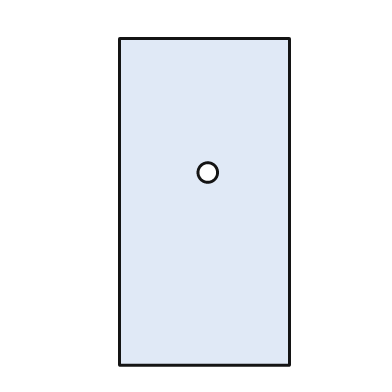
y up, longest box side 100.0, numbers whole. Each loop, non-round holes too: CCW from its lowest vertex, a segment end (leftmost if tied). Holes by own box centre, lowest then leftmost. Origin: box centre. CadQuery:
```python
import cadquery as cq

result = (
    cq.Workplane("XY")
    .moveTo(-26.0, -50.0)
    .lineTo(26.0, -50.0)
    .lineTo(26.0, 50.0)
    .lineTo(-26.0, 50.0)
    .close()
    .moveTo(1.0, 9.0)
    .circle(3.0)
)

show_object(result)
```